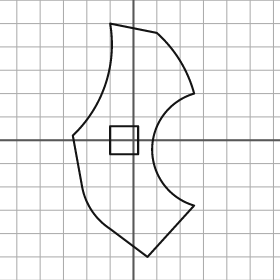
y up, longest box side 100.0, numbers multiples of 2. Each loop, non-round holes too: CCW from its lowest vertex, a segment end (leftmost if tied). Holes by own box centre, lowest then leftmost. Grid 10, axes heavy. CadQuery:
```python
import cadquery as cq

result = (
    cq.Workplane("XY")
    .moveTo(6.0, -50.0)
    .lineTo(26.0, -28.0)
    .threePointArc((8.0, -4.0), (26.0, 20.0))
    .threePointArc((20.0, 34.0), (10.0, 46.0))
    .lineTo(-10.0, 50.0)
    .threePointArc((-12.0, 24.0), (-26.0, 2.0))
    .lineTo(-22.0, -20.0)
    .threePointArc((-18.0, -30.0), (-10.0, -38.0))
    .close()
    .moveTo(-10.0, -6.0)
    .lineTo(2.0, -6.0)
    .lineTo(2.0, 6.0)
    .lineTo(-10.0, 6.0)
    .close()
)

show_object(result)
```